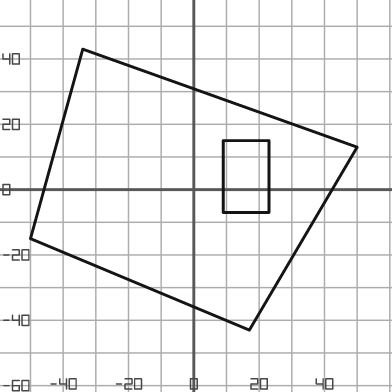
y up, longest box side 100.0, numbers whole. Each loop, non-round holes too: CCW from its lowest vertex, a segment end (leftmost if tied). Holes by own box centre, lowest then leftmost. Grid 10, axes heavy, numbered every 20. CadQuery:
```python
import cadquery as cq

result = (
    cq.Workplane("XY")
    .moveTo(17.0, -43.0)
    .lineTo(50.0, 13.0)
    .lineTo(-34.0, 43.0)
    .lineTo(-50.0, -15.0)
    .close()
    .moveTo(9.0, -7.0)
    .lineTo(23.0, -7.0)
    .lineTo(23.0, 15.0)
    .lineTo(9.0, 15.0)
    .close()
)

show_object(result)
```